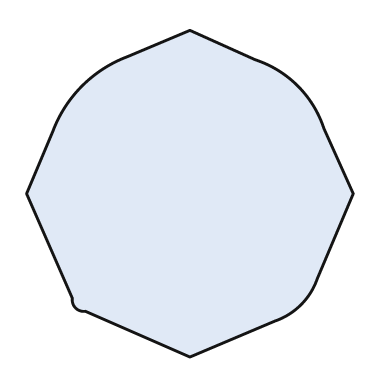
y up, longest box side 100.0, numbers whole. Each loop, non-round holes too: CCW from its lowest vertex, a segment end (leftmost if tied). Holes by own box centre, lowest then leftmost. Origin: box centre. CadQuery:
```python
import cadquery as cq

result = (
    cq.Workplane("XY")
    .moveTo(0.0, -50.0)
    .lineTo(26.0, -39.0)
    .threePointArc((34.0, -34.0), (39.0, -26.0))
    .lineTo(50.0, 0.0)
    .lineTo(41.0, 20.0)
    .threePointArc((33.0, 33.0), (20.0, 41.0))
    .lineTo(0.0, 50.0)
    .lineTo(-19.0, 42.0)
    .threePointArc((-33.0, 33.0), (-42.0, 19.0))
    .lineTo(-50.0, 0.0)
    .lineTo(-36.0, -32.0)
    .threePointArc((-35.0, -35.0), (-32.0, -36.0))
    .close()
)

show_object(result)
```